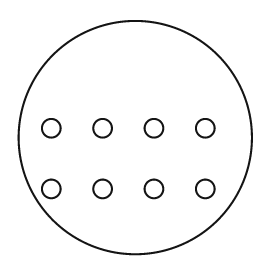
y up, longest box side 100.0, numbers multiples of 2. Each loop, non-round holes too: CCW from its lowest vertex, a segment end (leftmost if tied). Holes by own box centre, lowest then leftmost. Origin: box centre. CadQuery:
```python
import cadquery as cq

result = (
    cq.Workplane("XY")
    .moveTo(0.0, 0.0)
    .circle(50.0)
    .moveTo(-36.0, -22.0)
    .circle(4.0)
    .moveTo(-14.0, -22.0)
    .circle(4.0)
    .moveTo(8.0, -22.0)
    .circle(4.0)
    .moveTo(30.0, -22.0)
    .circle(4.0)
    .moveTo(-36.0, 4.0)
    .circle(4.0)
    .moveTo(-14.0, 4.0)
    .circle(4.0)
    .moveTo(8.0, 4.0)
    .circle(4.0)
    .moveTo(30.0, 4.0)
    .circle(4.0)
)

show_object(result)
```